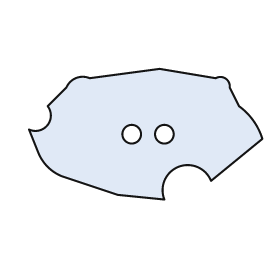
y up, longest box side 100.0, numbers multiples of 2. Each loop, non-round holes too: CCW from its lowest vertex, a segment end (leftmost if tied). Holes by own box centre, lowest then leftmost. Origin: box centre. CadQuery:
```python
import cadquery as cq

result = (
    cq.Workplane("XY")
    .moveTo(8.0, -28.0)
    .threePointArc((14.0, -14.0), (28.0, -20.0))
    .lineTo(50.0, -2.0)
    .threePointArc((46.0, 6.0), (40.0, 12.0))
    .lineTo(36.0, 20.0)
    .threePointArc((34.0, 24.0), (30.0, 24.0))
    .lineTo(6.0, 28.0)
    .lineTo(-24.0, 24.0)
    .threePointArc((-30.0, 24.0), (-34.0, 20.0))
    .lineTo(-42.0, 12.0)
    .threePointArc((-42.0, 4.0), (-50.0, 2.0))
    .lineTo(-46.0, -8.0)
    .threePointArc((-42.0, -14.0), (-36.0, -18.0))
    .lineTo(-12.0, -26.0)
    .close()
    .moveTo(-6.0, 0.0)
    .circle(4.0)
    .moveTo(8.0, 0.0)
    .circle(4.0)
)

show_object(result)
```